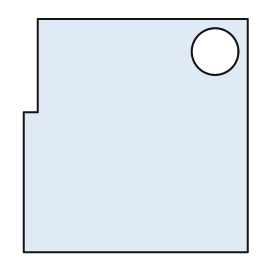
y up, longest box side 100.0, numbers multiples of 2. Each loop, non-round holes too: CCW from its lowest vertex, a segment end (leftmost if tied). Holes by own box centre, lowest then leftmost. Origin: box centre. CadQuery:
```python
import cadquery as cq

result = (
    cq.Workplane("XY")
    .moveTo(-48.0, -50.0)
    .lineTo(48.0, -50.0)
    .lineTo(48.0, 50.0)
    .lineTo(-42.0, 50.0)
    .lineTo(-42.0, 10.0)
    .lineTo(-48.0, 10.0)
    .close()
    .moveTo(34.0, 36.0)
    .circle(10.0)
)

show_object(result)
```